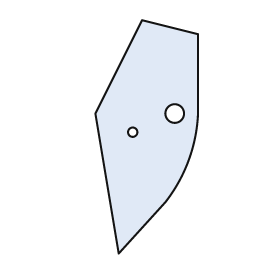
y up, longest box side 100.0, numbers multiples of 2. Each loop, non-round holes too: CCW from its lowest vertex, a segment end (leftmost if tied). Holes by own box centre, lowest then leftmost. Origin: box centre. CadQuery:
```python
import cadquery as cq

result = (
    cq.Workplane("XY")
    .moveTo(-12.0, -50.0)
    .lineTo(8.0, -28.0)
    .threePointArc((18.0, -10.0), (22.0, 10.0))
    .lineTo(22.0, 44.0)
    .lineTo(-2.0, 50.0)
    .lineTo(-22.0, 10.0)
    .close()
    .moveTo(-6.0, 2.0)
    .circle(2.0)
    .moveTo(12.0, 10.0)
    .circle(4.0)
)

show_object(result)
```